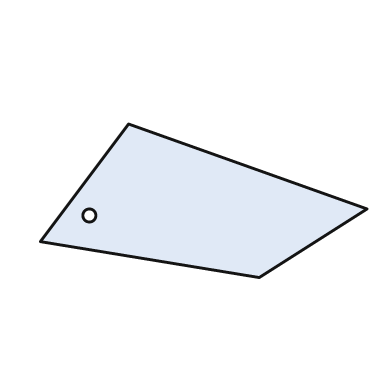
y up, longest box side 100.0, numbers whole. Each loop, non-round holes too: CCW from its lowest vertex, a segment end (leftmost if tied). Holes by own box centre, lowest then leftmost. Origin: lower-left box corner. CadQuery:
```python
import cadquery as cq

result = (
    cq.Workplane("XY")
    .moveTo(67.0, 0.0)
    .lineTo(100.0, 21.0)
    .lineTo(27.0, 47.0)
    .lineTo(0.0, 11.0)
    .close()
    .moveTo(15.0, 19.0)
    .circle(2.0)
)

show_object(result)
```